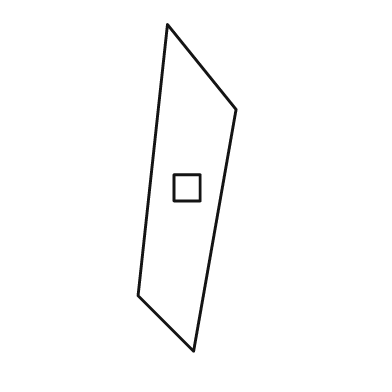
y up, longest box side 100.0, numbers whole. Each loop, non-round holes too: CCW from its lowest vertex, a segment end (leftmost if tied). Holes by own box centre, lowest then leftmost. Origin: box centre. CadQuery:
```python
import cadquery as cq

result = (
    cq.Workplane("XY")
    .moveTo(2.0, -50.0)
    .lineTo(15.0, 24.0)
    .lineTo(-6.0, 50.0)
    .lineTo(-15.0, -33.0)
    .close()
    .moveTo(-4.0, -4.0)
    .lineTo(4.0, -4.0)
    .lineTo(4.0, 4.0)
    .lineTo(-4.0, 4.0)
    .close()
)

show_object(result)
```